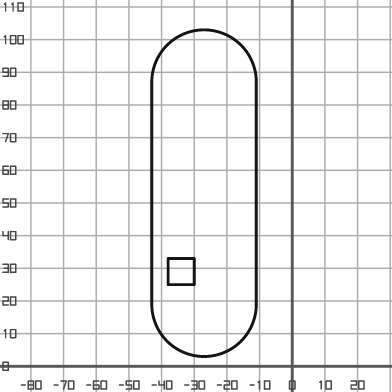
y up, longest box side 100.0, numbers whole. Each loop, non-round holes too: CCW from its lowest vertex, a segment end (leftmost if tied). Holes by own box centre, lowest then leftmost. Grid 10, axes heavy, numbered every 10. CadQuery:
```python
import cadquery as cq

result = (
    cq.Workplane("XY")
    .moveTo(-43.0, 19.0)
    .threePointArc((-27.0, 3.0), (-11.0, 19.0))
    .lineTo(-11.0, 87.0)
    .threePointArc((-27.0, 103.0), (-43.0, 87.0))
    .close()
    .moveTo(-38.0, 25.0)
    .lineTo(-30.0, 25.0)
    .lineTo(-30.0, 33.0)
    .lineTo(-38.0, 33.0)
    .close()
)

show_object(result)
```